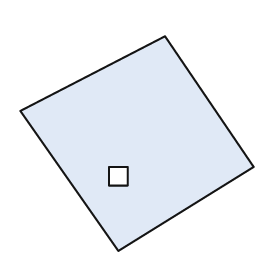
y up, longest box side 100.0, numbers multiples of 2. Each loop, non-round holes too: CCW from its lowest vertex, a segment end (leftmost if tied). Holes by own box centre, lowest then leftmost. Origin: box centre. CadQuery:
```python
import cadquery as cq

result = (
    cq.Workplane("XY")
    .moveTo(-8.0, -46.0)
    .lineTo(50.0, -10.0)
    .lineTo(12.0, 46.0)
    .lineTo(-50.0, 14.0)
    .close()
    .moveTo(-12.0, -18.0)
    .lineTo(-4.0, -18.0)
    .lineTo(-4.0, -10.0)
    .lineTo(-12.0, -10.0)
    .close()
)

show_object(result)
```